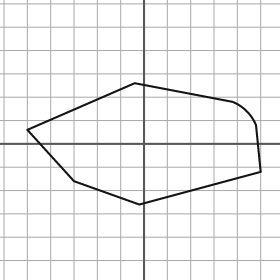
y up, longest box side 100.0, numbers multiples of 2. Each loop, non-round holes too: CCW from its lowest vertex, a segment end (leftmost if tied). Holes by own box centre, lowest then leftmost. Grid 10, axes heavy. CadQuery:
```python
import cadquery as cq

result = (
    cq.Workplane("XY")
    .moveTo(-2.0, -26.0)
    .lineTo(50.0, -12.0)
    .lineTo(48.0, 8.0)
    .threePointArc((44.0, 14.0), (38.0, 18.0))
    .lineTo(-4.0, 26.0)
    .lineTo(-50.0, 6.0)
    .lineTo(-30.0, -16.0)
    .close()
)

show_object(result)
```